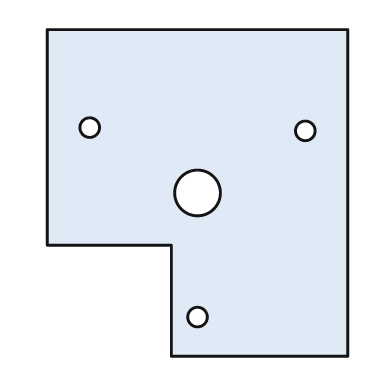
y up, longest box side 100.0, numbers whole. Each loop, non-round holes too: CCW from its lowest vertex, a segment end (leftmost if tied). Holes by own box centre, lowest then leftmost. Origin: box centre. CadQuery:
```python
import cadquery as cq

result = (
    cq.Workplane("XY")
    .moveTo(-8.0, -50.0)
    .lineTo(46.0, -50.0)
    .lineTo(46.0, 50.0)
    .lineTo(-46.0, 50.0)
    .lineTo(-46.0, -16.0)
    .lineTo(-8.0, -16.0)
    .close()
    .moveTo(0.0, -38.0)
    .circle(3.0)
    .moveTo(0.0, 0.0)
    .circle(7.0)
    .moveTo(33.0, 19.0)
    .circle(3.0)
    .moveTo(-33.0, 20.0)
    .circle(3.0)
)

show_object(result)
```